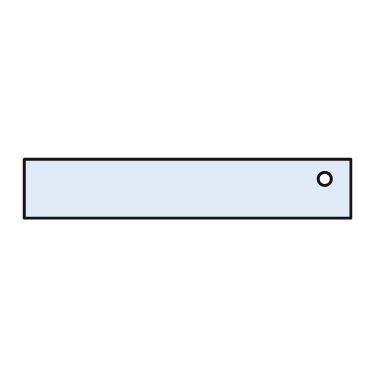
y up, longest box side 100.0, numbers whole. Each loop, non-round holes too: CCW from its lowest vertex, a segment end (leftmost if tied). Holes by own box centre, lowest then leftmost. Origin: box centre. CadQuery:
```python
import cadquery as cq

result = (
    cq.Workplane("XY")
    .moveTo(-50.0, -9.0)
    .lineTo(50.0, -9.0)
    .lineTo(50.0, 9.0)
    .lineTo(-50.0, 9.0)
    .close()
    .moveTo(42.0, 3.0)
    .circle(2.0)
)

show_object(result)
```